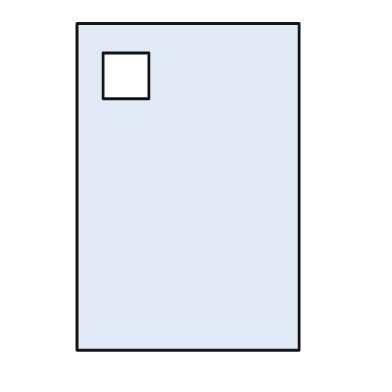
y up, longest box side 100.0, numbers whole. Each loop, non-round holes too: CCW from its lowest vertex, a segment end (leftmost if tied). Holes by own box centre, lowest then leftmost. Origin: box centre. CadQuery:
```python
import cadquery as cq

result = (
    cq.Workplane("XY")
    .moveTo(-34.0, -50.0)
    .lineTo(34.0, -50.0)
    .lineTo(34.0, 50.0)
    .lineTo(-34.0, 50.0)
    .close()
    .moveTo(-26.0, 27.0)
    .lineTo(-12.0, 27.0)
    .lineTo(-12.0, 41.0)
    .lineTo(-26.0, 41.0)
    .close()
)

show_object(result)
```